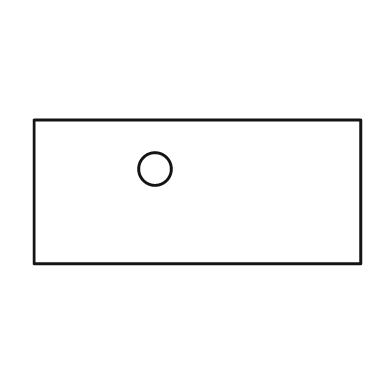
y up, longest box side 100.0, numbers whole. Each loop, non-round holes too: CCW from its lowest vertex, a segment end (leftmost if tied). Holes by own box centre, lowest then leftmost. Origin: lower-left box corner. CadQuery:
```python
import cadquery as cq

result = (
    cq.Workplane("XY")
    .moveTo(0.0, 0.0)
    .lineTo(100.0, 0.0)
    .lineTo(100.0, 44.0)
    .lineTo(0.0, 44.0)
    .close()
    .moveTo(37.0, 29.0)
    .circle(5.0)
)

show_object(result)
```